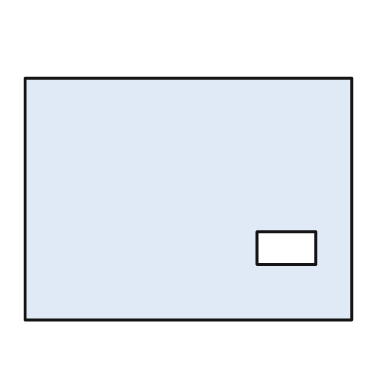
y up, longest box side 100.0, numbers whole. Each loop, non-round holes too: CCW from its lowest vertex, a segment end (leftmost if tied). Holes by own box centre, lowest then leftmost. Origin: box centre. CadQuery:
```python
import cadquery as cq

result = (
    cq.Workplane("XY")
    .moveTo(-50.0, -37.0)
    .lineTo(50.0, -37.0)
    .lineTo(50.0, 37.0)
    .lineTo(-50.0, 37.0)
    .close()
    .moveTo(21.0, -20.0)
    .lineTo(39.0, -20.0)
    .lineTo(39.0, -10.0)
    .lineTo(21.0, -10.0)
    .close()
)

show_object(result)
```